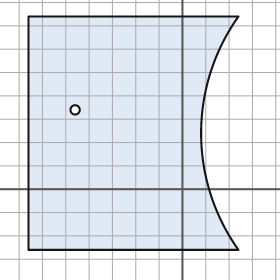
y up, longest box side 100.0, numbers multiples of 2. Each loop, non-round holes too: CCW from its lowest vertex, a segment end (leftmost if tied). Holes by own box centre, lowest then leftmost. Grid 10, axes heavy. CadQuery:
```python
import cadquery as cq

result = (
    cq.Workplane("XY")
    .moveTo(-66.0, -26.0)
    .lineTo(24.0, -26.0)
    .threePointArc((8.0, 24.0), (24.0, 74.0))
    .lineTo(-66.0, 74.0)
    .close()
    .moveTo(-46.0, 34.0)
    .circle(2.0)
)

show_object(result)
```